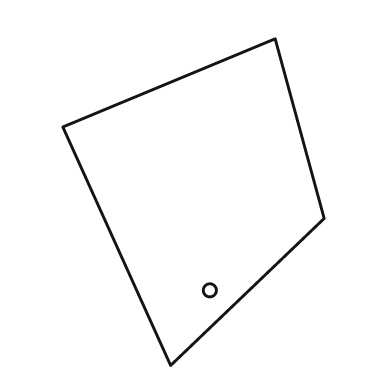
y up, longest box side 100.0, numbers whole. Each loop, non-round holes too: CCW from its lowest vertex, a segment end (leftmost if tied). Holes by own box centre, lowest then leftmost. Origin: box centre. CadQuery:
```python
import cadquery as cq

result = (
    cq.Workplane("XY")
    .moveTo(-7.0, -50.0)
    .lineTo(40.0, -5.0)
    .lineTo(25.0, 50.0)
    .lineTo(-40.0, 23.0)
    .close()
    .moveTo(5.0, -27.0)
    .circle(2.0)
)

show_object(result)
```